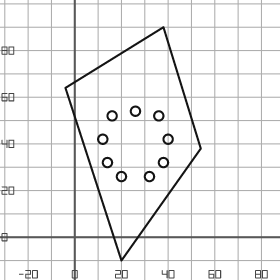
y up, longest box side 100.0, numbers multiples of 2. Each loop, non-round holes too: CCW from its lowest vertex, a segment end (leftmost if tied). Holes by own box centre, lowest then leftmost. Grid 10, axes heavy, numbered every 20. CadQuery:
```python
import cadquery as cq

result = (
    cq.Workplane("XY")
    .moveTo(20.0, -10.0)
    .lineTo(54.0, 38.0)
    .lineTo(38.0, 90.0)
    .lineTo(-4.0, 64.0)
    .close()
    .moveTo(20.0, 26.0)
    .circle(2.0)
    .moveTo(32.0, 26.0)
    .circle(2.0)
    .moveTo(14.0, 32.0)
    .circle(2.0)
    .moveTo(38.0, 32.0)
    .circle(2.0)
    .moveTo(12.0, 42.0)
    .circle(2.0)
    .moveTo(40.0, 42.0)
    .circle(2.0)
    .moveTo(16.0, 52.0)
    .circle(2.0)
    .moveTo(36.0, 52.0)
    .circle(2.0)
    .moveTo(26.0, 54.0)
    .circle(2.0)
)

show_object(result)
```